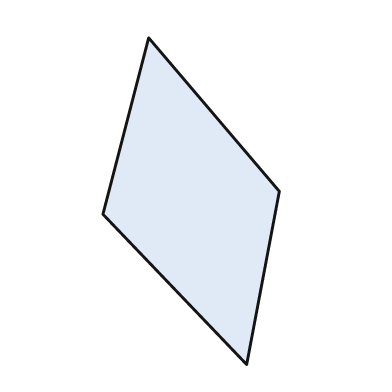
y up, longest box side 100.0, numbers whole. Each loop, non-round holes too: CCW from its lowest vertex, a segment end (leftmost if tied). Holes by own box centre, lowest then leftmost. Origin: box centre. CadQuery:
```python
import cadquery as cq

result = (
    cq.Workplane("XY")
    .moveTo(17.0, -50.0)
    .lineTo(27.0, 3.0)
    .lineTo(-13.0, 50.0)
    .lineTo(-27.0, -4.0)
    .close()
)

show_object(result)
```